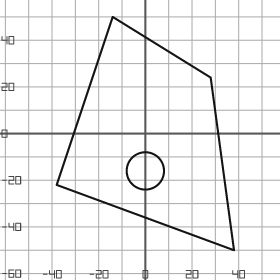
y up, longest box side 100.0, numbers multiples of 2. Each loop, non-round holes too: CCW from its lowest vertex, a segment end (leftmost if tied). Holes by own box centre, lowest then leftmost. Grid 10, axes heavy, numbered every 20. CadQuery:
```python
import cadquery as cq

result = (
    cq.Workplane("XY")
    .moveTo(38.0, -50.0)
    .lineTo(28.0, 24.0)
    .lineTo(-14.0, 50.0)
    .lineTo(-38.0, -22.0)
    .close()
    .moveTo(0.0, -16.0)
    .circle(8.0)
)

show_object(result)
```